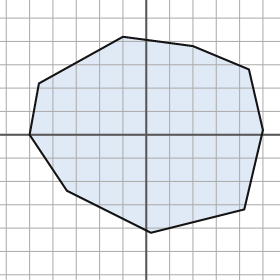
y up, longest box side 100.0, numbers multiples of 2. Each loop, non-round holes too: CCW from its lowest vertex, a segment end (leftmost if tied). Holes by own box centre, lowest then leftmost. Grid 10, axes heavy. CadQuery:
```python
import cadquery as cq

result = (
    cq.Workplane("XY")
    .moveTo(2.0, -42.0)
    .lineTo(42.0, -32.0)
    .lineTo(50.0, 2.0)
    .lineTo(44.0, 28.0)
    .lineTo(20.0, 38.0)
    .lineTo(-10.0, 42.0)
    .lineTo(-46.0, 22.0)
    .lineTo(-50.0, 0.0)
    .lineTo(-34.0, -24.0)
    .close()
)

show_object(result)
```